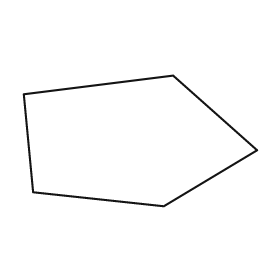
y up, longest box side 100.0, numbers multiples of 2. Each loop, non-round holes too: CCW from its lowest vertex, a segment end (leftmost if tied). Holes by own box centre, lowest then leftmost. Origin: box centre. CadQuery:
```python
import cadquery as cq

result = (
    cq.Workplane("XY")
    .moveTo(10.0, -28.0)
    .lineTo(50.0, -4.0)
    .lineTo(14.0, 28.0)
    .lineTo(-50.0, 20.0)
    .lineTo(-46.0, -22.0)
    .close()
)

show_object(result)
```